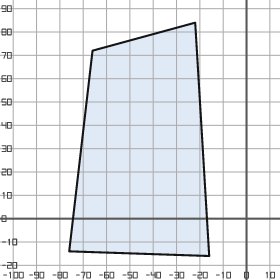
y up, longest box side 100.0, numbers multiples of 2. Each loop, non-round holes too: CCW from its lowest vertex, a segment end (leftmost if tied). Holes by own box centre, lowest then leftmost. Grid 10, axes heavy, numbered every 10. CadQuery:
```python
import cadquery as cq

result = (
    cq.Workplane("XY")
    .moveTo(-16.0, -16.0)
    .lineTo(-22.0, 84.0)
    .lineTo(-66.0, 72.0)
    .lineTo(-76.0, -14.0)
    .close()
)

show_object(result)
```